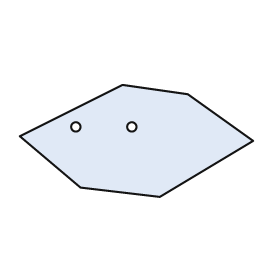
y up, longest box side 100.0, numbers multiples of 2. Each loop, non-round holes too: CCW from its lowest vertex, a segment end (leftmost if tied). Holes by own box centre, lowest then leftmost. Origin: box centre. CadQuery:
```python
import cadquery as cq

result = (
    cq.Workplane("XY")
    .moveTo(10.0, -24.0)
    .lineTo(50.0, 0.0)
    .lineTo(22.0, 20.0)
    .lineTo(-6.0, 24.0)
    .lineTo(-50.0, 2.0)
    .lineTo(-24.0, -20.0)
    .close()
    .moveTo(-26.0, 6.0)
    .circle(2.0)
    .moveTo(-2.0, 6.0)
    .circle(2.0)
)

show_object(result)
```